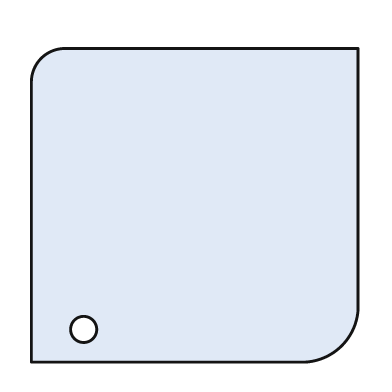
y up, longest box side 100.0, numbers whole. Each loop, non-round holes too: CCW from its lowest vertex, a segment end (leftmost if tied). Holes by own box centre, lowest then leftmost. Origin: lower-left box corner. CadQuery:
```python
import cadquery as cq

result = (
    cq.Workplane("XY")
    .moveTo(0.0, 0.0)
    .lineTo(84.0, 0.0)
    .threePointArc((95.0, 5.0), (100.0, 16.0))
    .lineTo(100.0, 96.0)
    .lineTo(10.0, 96.0)
    .threePointArc((3.0, 93.0), (0.0, 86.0))
    .close()
    .moveTo(16.0, 10.0)
    .circle(4.0)
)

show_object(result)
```